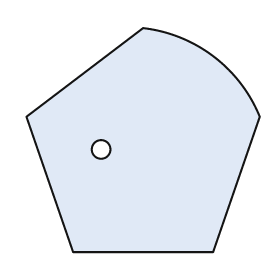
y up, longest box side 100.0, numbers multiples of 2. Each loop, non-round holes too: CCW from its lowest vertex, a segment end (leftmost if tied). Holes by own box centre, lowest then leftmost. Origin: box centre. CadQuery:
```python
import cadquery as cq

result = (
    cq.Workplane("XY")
    .moveTo(-30.0, -48.0)
    .lineTo(30.0, -48.0)
    .lineTo(50.0, 10.0)
    .threePointArc((30.0, 36.0), (0.0, 48.0))
    .lineTo(-50.0, 10.0)
    .close()
    .moveTo(-18.0, -4.0)
    .circle(4.0)
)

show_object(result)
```